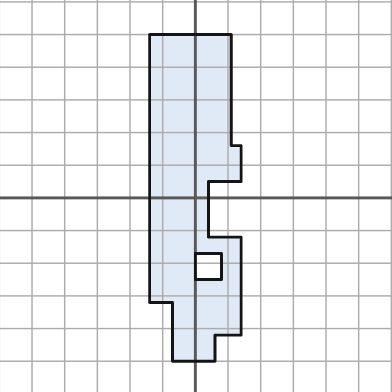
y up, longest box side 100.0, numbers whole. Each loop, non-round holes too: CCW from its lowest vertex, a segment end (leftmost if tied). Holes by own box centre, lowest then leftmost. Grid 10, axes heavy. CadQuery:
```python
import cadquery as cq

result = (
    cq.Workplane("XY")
    .moveTo(-7.0, -50.0)
    .lineTo(6.0, -50.0)
    .lineTo(6.0, -42.0)
    .lineTo(14.0, -42.0)
    .lineTo(14.0, -12.0)
    .lineTo(4.0, -12.0)
    .lineTo(4.0, 5.0)
    .lineTo(14.0, 5.0)
    .lineTo(14.0, 16.0)
    .lineTo(11.0, 16.0)
    .lineTo(11.0, 50.0)
    .lineTo(-14.0, 50.0)
    .lineTo(-14.0, -32.0)
    .lineTo(-7.0, -32.0)
    .close()
    .moveTo(0.0, -25.0)
    .lineTo(8.0, -25.0)
    .lineTo(8.0, -17.0)
    .lineTo(0.0, -17.0)
    .close()
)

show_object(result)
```